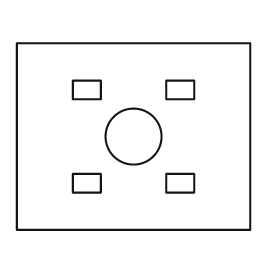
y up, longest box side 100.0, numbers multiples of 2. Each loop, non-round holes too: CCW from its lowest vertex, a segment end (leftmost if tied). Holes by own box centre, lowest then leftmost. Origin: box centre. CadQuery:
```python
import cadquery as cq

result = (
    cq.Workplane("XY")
    .moveTo(-50.0, -40.0)
    .lineTo(50.0, -40.0)
    .lineTo(50.0, 40.0)
    .lineTo(-50.0, 40.0)
    .close()
    .moveTo(-26.0, -24.0)
    .lineTo(-14.0, -24.0)
    .lineTo(-14.0, -16.0)
    .lineTo(-26.0, -16.0)
    .close()
    .moveTo(14.0, -24.0)
    .lineTo(26.0, -24.0)
    .lineTo(26.0, -16.0)
    .lineTo(14.0, -16.0)
    .close()
    .moveTo(0.0, 0.0)
    .circle(12.0)
    .moveTo(-26.0, 16.0)
    .lineTo(-14.0, 16.0)
    .lineTo(-14.0, 24.0)
    .lineTo(-26.0, 24.0)
    .close()
    .moveTo(14.0, 16.0)
    .lineTo(26.0, 16.0)
    .lineTo(26.0, 24.0)
    .lineTo(14.0, 24.0)
    .close()
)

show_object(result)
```